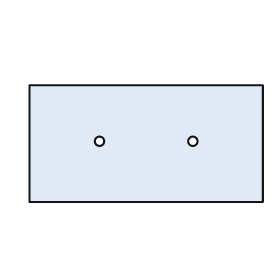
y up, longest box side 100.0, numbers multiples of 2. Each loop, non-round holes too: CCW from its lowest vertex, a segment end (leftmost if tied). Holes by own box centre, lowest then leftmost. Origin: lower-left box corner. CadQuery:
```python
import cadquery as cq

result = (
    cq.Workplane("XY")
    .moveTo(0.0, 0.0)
    .lineTo(100.0, 0.0)
    .lineTo(100.0, 50.0)
    .lineTo(0.0, 50.0)
    .close()
    .moveTo(30.0, 26.0)
    .circle(2.0)
    .moveTo(70.0, 26.0)
    .circle(2.0)
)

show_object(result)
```